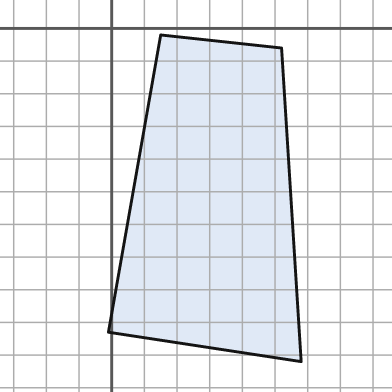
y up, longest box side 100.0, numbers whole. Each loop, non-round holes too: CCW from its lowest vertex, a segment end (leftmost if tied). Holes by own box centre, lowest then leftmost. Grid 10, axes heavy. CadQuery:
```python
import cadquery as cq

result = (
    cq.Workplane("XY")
    .moveTo(58.0, -102.0)
    .lineTo(52.0, -6.0)
    .lineTo(15.0, -2.0)
    .lineTo(-1.0, -93.0)
    .close()
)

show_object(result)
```